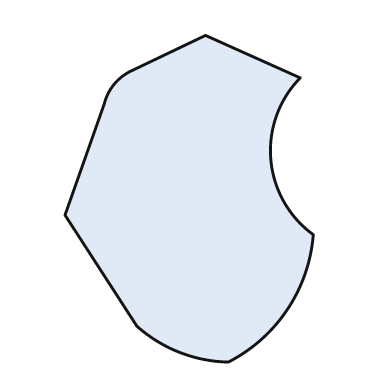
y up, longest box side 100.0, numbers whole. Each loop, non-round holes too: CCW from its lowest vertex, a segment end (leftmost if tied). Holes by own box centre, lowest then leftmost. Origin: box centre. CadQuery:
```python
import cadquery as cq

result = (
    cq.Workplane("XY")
    .moveTo(12.0, -50.0)
    .threePointArc((30.0, -34.0), (38.0, -11.0))
    .threePointArc((25.0, 12.0), (34.0, 37.0))
    .lineTo(5.0, 50.0)
    .lineTo(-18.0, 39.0)
    .threePointArc((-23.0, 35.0), (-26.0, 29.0))
    .lineTo(-38.0, -5.0)
    .lineTo(-16.0, -39.0)
    .threePointArc((-3.0, -47.0), (12.0, -50.0))
    .close()
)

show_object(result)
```